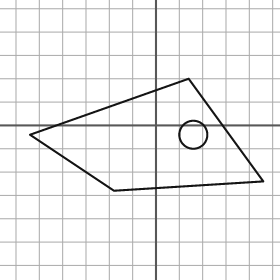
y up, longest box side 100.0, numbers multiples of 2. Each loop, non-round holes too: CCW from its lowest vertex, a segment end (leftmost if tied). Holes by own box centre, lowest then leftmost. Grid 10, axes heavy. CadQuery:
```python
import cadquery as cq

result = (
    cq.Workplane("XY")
    .moveTo(-18.0, -28.0)
    .lineTo(46.0, -24.0)
    .lineTo(14.0, 20.0)
    .lineTo(-54.0, -4.0)
    .close()
    .moveTo(16.0, -4.0)
    .circle(6.0)
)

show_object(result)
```